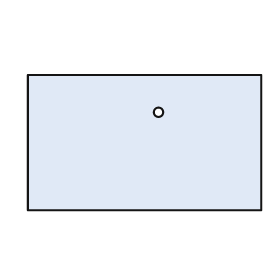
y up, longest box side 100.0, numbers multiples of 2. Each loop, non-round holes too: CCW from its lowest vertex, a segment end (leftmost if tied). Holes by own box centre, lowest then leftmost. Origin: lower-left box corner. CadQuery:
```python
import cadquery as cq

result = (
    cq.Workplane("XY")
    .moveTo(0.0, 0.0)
    .lineTo(100.0, 0.0)
    .lineTo(100.0, 58.0)
    .lineTo(0.0, 58.0)
    .close()
    .moveTo(56.0, 42.0)
    .circle(2.0)
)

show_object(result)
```